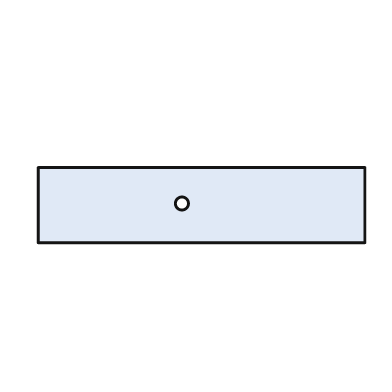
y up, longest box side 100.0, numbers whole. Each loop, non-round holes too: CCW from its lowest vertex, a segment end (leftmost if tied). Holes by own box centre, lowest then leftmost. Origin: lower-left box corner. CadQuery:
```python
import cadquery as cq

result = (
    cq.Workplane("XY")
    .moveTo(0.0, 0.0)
    .lineTo(100.0, 0.0)
    .lineTo(100.0, 23.0)
    .lineTo(0.0, 23.0)
    .close()
    .moveTo(44.0, 12.0)
    .circle(2.0)
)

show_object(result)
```